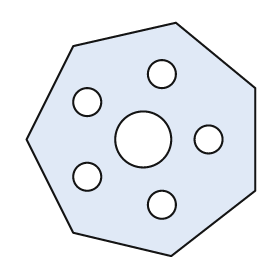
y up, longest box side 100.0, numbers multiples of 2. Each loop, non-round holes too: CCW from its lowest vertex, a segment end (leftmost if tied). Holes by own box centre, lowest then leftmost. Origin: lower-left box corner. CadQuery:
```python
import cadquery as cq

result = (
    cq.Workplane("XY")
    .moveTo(62.0, 0.0)
    .lineTo(98.0, 28.0)
    .lineTo(98.0, 72.0)
    .lineTo(64.0, 100.0)
    .lineTo(20.0, 90.0)
    .lineTo(0.0, 50.0)
    .lineTo(20.0, 10.0)
    .close()
    .moveTo(58.0, 22.0)
    .circle(6.0)
    .moveTo(26.0, 34.0)
    .circle(6.0)
    .moveTo(50.0, 50.0)
    .circle(12.0)
    .moveTo(78.0, 50.0)
    .circle(6.0)
    .moveTo(26.0, 66.0)
    .circle(6.0)
    .moveTo(58.0, 78.0)
    .circle(6.0)
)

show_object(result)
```